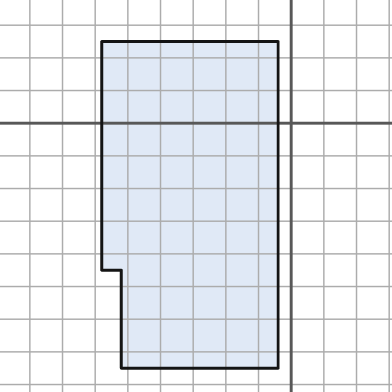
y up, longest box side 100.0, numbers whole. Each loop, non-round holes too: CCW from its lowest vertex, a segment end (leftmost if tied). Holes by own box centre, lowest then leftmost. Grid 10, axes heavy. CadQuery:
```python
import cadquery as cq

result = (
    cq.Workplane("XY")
    .moveTo(-52.0, -75.0)
    .lineTo(-4.0, -75.0)
    .lineTo(-4.0, 25.0)
    .lineTo(-58.0, 25.0)
    .lineTo(-58.0, -45.0)
    .lineTo(-52.0, -45.0)
    .close()
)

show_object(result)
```